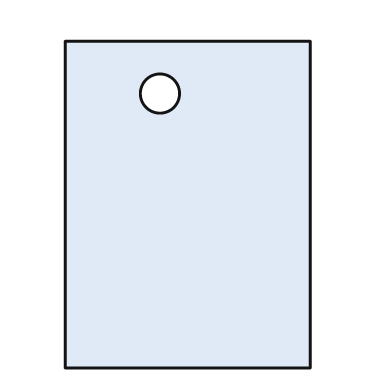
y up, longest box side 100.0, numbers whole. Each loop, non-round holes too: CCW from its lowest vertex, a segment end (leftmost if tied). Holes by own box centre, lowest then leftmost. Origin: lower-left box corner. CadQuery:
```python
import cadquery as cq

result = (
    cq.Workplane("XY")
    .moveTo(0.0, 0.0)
    .lineTo(75.0, 0.0)
    .lineTo(75.0, 100.0)
    .lineTo(0.0, 100.0)
    .close()
    .moveTo(29.0, 84.0)
    .circle(6.0)
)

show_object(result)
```